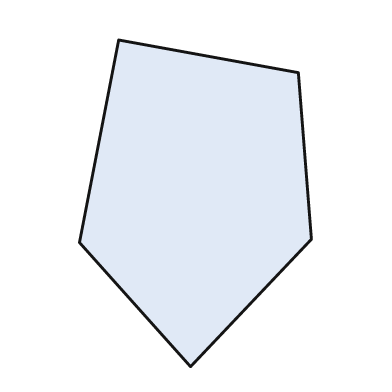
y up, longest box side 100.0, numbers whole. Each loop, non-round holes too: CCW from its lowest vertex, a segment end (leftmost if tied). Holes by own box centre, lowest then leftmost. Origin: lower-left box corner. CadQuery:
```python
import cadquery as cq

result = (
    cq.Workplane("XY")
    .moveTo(34.0, 0.0)
    .lineTo(71.0, 39.0)
    .lineTo(67.0, 90.0)
    .lineTo(12.0, 100.0)
    .lineTo(0.0, 38.0)
    .close()
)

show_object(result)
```